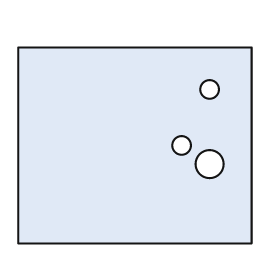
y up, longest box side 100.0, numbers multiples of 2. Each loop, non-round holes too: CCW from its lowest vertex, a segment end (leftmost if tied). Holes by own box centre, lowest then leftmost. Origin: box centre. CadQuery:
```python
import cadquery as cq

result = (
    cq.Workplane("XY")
    .moveTo(-50.0, -42.0)
    .lineTo(50.0, -42.0)
    .lineTo(50.0, 42.0)
    .lineTo(-50.0, 42.0)
    .close()
    .moveTo(32.0, -8.0)
    .circle(6.0)
    .moveTo(20.0, 0.0)
    .circle(4.0)
    .moveTo(32.0, 24.0)
    .circle(4.0)
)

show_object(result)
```